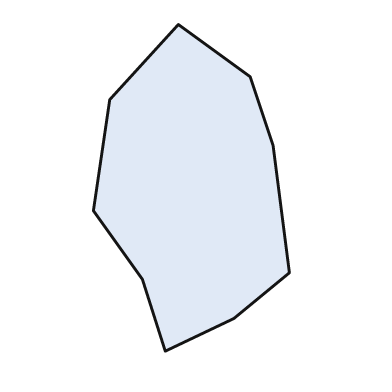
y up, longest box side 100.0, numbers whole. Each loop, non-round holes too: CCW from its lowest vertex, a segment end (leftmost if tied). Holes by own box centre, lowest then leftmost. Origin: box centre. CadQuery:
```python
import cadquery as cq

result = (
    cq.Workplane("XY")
    .moveTo(-8.0, -50.0)
    .lineTo(13.0, -40.0)
    .lineTo(30.0, -26.0)
    .lineTo(25.0, 13.0)
    .lineTo(18.0, 34.0)
    .lineTo(-4.0, 50.0)
    .lineTo(-25.0, 27.0)
    .lineTo(-30.0, -7.0)
    .lineTo(-15.0, -28.0)
    .close()
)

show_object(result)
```